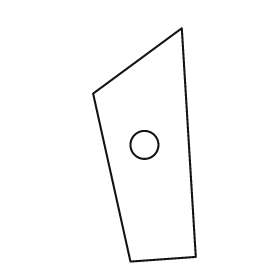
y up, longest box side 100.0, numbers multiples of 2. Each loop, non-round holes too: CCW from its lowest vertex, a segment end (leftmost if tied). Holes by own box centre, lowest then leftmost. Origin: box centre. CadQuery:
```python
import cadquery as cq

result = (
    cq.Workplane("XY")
    .moveTo(-6.0, -50.0)
    .lineTo(22.0, -48.0)
    .lineTo(16.0, 50.0)
    .lineTo(-22.0, 22.0)
    .close()
    .moveTo(0.0, 0.0)
    .circle(6.0)
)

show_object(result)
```